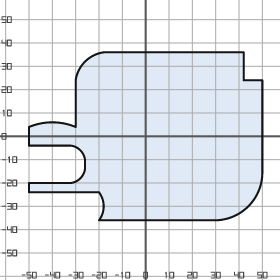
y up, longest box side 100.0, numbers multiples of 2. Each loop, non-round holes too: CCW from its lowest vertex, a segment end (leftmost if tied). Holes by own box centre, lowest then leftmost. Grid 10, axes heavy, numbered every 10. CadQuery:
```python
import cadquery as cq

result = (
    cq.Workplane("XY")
    .moveTo(-20.0, -36.0)
    .lineTo(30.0, -36.0)
    .threePointArc((44.0, -30.0), (50.0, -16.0))
    .lineTo(50.0, 24.0)
    .lineTo(42.0, 24.0)
    .lineTo(42.0, 36.0)
    .lineTo(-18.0, 36.0)
    .threePointArc((-26.0, 32.0), (-30.0, 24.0))
    .lineTo(-30.0, 4.0)
    .threePointArc((-40.0, 6.0), (-50.0, 4.0))
    .lineTo(-50.0, -4.0)
    .lineTo(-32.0, -4.0)
    .threePointArc((-28.0, -6.0), (-26.0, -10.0))
    .lineTo(-26.0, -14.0)
    .threePointArc((-28.0, -18.0), (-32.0, -20.0))
    .lineTo(-50.0, -20.0)
    .lineTo(-50.0, -24.0)
    .lineTo(-20.0, -24.0)
    .threePointArc((-18.0, -30.0), (-20.0, -36.0))
    .close()
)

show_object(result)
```